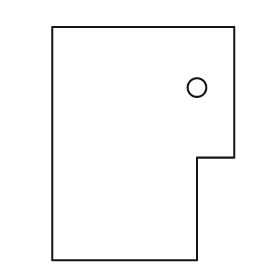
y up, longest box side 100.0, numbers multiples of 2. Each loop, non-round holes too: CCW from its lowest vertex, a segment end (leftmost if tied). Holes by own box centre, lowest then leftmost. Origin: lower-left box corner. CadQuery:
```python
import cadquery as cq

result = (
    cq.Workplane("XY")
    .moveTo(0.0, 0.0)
    .lineTo(62.0, 0.0)
    .lineTo(62.0, 44.0)
    .lineTo(78.0, 44.0)
    .lineTo(78.0, 100.0)
    .lineTo(0.0, 100.0)
    .close()
    .moveTo(62.0, 74.0)
    .circle(4.0)
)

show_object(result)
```